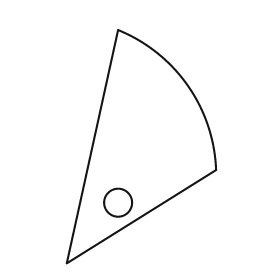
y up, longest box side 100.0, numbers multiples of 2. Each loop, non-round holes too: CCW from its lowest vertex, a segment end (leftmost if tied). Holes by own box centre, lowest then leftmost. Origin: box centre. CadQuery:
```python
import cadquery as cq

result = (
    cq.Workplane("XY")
    .moveTo(-32.0, -50.0)
    .lineTo(32.0, -10.0)
    .threePointArc((20.0, 26.0), (-10.0, 50.0))
    .close()
    .moveTo(-10.0, -24.0)
    .circle(6.0)
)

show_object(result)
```